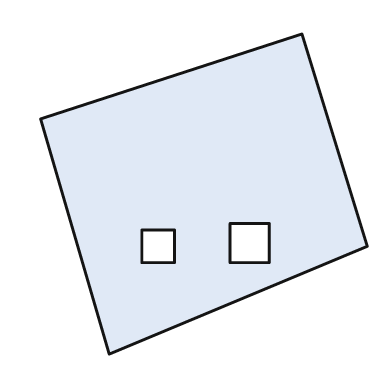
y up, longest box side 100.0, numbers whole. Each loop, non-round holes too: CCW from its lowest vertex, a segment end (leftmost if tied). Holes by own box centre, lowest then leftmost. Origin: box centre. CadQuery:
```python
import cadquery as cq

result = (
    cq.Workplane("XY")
    .moveTo(-29.0, -49.0)
    .lineTo(50.0, -16.0)
    .lineTo(30.0, 49.0)
    .lineTo(-50.0, 23.0)
    .close()
    .moveTo(-19.0, -21.0)
    .lineTo(-9.0, -21.0)
    .lineTo(-9.0, -11.0)
    .lineTo(-19.0, -11.0)
    .close()
    .moveTo(8.0, -21.0)
    .lineTo(20.0, -21.0)
    .lineTo(20.0, -9.0)
    .lineTo(8.0, -9.0)
    .close()
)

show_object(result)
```